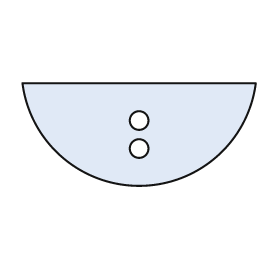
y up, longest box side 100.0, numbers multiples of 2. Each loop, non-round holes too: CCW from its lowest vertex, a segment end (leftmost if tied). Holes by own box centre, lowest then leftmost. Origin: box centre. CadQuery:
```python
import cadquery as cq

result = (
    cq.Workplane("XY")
    .moveTo(-50.0, 22.0)
    .threePointArc((0.0, -22.0), (50.0, 22.0))
    .close()
    .moveTo(0.0, -6.0)
    .circle(4.0)
    .moveTo(0.0, 6.0)
    .circle(4.0)
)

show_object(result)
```